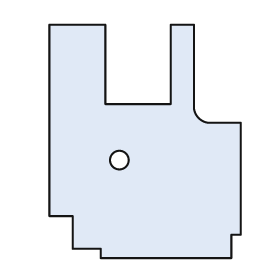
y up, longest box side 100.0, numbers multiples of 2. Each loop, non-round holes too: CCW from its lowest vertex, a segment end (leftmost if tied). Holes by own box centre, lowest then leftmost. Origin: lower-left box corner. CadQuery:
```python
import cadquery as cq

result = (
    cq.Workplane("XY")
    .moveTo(22.0, 0.0)
    .lineTo(78.0, 0.0)
    .lineTo(78.0, 10.0)
    .lineTo(82.0, 10.0)
    .lineTo(82.0, 58.0)
    .lineTo(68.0, 58.0)
    .threePointArc((64.0, 60.0), (62.0, 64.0))
    .lineTo(62.0, 100.0)
    .lineTo(52.0, 100.0)
    .lineTo(52.0, 66.0)
    .lineTo(24.0, 66.0)
    .lineTo(24.0, 100.0)
    .lineTo(0.0, 100.0)
    .lineTo(0.0, 18.0)
    .lineTo(10.0, 18.0)
    .lineTo(10.0, 4.0)
    .lineTo(22.0, 4.0)
    .close()
    .moveTo(30.0, 42.0)
    .circle(4.0)
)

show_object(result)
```